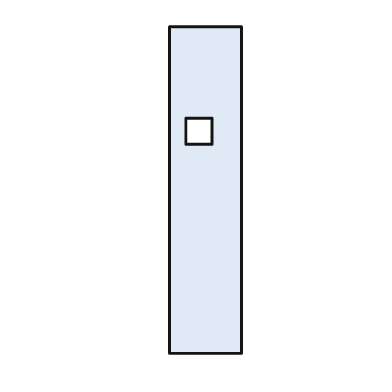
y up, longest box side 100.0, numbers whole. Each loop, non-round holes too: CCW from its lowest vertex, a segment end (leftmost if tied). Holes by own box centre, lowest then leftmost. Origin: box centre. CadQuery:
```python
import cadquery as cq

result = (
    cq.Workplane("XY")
    .moveTo(-11.0, -50.0)
    .lineTo(11.0, -50.0)
    .lineTo(11.0, 50.0)
    .lineTo(-11.0, 50.0)
    .close()
    .moveTo(-6.0, 14.0)
    .lineTo(2.0, 14.0)
    .lineTo(2.0, 22.0)
    .lineTo(-6.0, 22.0)
    .close()
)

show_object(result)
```